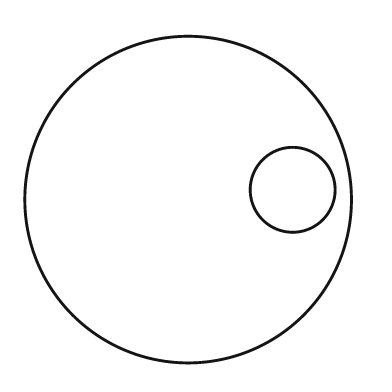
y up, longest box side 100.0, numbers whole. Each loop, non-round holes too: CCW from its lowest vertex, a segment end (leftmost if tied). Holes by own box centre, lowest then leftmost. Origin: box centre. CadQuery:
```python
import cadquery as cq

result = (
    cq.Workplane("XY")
    .moveTo(0.0, 0.0)
    .circle(50.0)
    .moveTo(32.0, 3.0)
    .circle(13.0)
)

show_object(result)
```